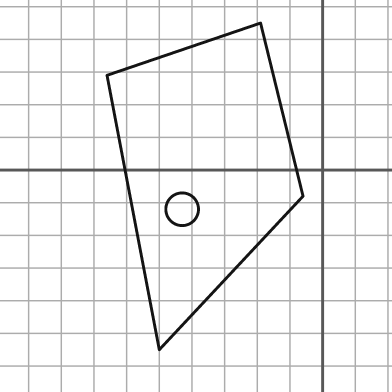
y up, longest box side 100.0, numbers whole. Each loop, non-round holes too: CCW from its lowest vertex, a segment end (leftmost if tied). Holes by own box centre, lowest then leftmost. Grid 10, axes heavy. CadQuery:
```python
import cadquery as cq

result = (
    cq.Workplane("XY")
    .moveTo(-50.0, -55.0)
    .lineTo(-6.0, -8.0)
    .lineTo(-19.0, 45.0)
    .lineTo(-66.0, 29.0)
    .close()
    .moveTo(-43.0, -12.0)
    .circle(5.0)
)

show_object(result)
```